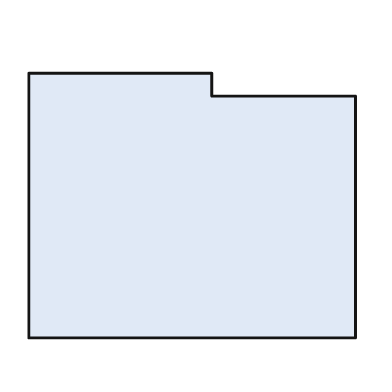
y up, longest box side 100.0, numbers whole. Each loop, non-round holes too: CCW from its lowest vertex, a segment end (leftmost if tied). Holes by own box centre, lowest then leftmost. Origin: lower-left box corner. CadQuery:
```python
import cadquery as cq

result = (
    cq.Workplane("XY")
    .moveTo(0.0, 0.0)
    .lineTo(100.0, 0.0)
    .lineTo(100.0, 74.0)
    .lineTo(56.0, 74.0)
    .lineTo(56.0, 81.0)
    .lineTo(0.0, 81.0)
    .close()
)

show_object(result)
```